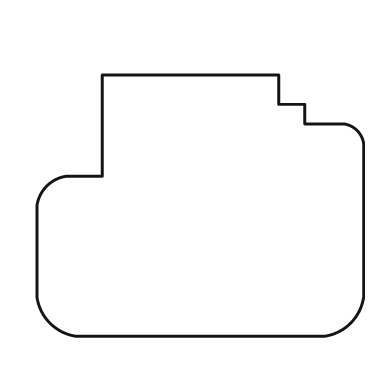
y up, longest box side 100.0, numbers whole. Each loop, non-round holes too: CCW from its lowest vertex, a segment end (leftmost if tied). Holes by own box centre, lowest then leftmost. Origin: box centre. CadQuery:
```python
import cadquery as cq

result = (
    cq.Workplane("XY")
    .moveTo(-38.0, -40.0)
    .lineTo(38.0, -40.0)
    .threePointArc((46.0, -36.0), (50.0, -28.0))
    .lineTo(50.0, 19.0)
    .threePointArc((48.0, 23.0), (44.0, 25.0))
    .lineTo(32.0, 25.0)
    .lineTo(32.0, 31.0)
    .lineTo(24.0, 31.0)
    .lineTo(24.0, 40.0)
    .lineTo(-30.0, 40.0)
    .lineTo(-30.0, 9.0)
    .lineTo(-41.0, 9.0)
    .threePointArc((-47.0, 6.0), (-50.0, 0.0))
    .lineTo(-50.0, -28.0)
    .threePointArc((-46.0, -36.0), (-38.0, -40.0))
    .close()
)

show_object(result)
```